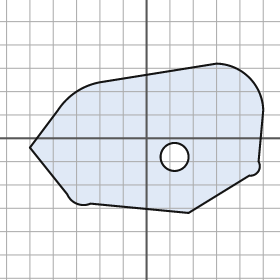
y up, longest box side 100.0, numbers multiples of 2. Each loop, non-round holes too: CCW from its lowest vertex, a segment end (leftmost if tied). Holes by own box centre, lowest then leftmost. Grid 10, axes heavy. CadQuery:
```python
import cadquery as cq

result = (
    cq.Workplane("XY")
    .moveTo(18.0, -32.0)
    .lineTo(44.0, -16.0)
    .threePointArc((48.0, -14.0), (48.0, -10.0))
    .lineTo(50.0, 12.0)
    .threePointArc((44.0, 26.0), (30.0, 32.0))
    .lineTo(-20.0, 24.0)
    .threePointArc((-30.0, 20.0), (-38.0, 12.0))
    .lineTo(-50.0, -4.0)
    .lineTo(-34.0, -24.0)
    .threePointArc((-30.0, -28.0), (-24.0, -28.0))
    .close()
    .moveTo(12.0, -8.0)
    .circle(6.0)
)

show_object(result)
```